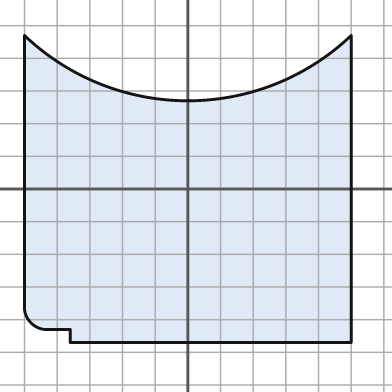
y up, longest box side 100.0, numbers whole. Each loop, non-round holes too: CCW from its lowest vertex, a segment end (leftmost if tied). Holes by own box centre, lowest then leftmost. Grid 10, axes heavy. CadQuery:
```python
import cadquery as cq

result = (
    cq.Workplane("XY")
    .moveTo(-36.0, -47.0)
    .lineTo(50.0, -47.0)
    .lineTo(50.0, 47.0)
    .threePointArc((0.0, 27.0), (-50.0, 47.0))
    .lineTo(-50.0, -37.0)
    .threePointArc((-48.0, -41.0), (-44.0, -43.0))
    .lineTo(-36.0, -43.0)
    .close()
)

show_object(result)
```